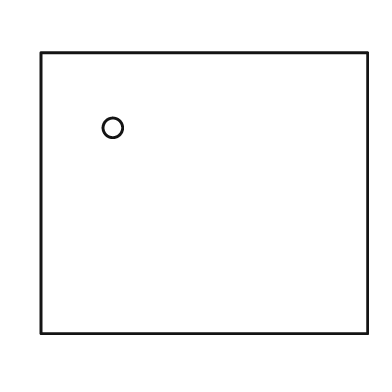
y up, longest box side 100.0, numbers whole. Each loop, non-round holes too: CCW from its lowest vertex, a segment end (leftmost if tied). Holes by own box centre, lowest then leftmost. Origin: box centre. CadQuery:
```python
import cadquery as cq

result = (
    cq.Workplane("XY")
    .moveTo(-50.0, -43.0)
    .lineTo(50.0, -43.0)
    .lineTo(50.0, 43.0)
    .lineTo(-50.0, 43.0)
    .close()
    .moveTo(-28.0, 20.0)
    .circle(3.0)
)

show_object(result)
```